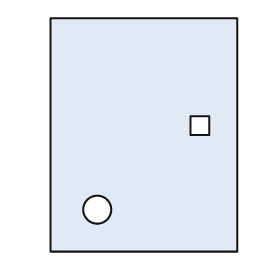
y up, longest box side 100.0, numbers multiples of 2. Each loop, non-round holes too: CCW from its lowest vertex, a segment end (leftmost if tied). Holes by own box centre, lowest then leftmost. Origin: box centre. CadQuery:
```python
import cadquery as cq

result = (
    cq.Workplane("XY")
    .moveTo(-40.0, -50.0)
    .lineTo(40.0, -50.0)
    .lineTo(40.0, 50.0)
    .lineTo(-40.0, 50.0)
    .close()
    .moveTo(-20.0, -32.0)
    .circle(6.0)
    .moveTo(20.0, 0.0)
    .lineTo(28.0, 0.0)
    .lineTo(28.0, 8.0)
    .lineTo(20.0, 8.0)
    .close()
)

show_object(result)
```